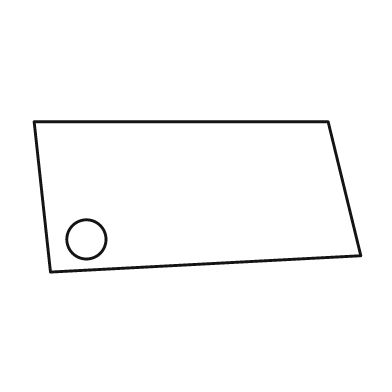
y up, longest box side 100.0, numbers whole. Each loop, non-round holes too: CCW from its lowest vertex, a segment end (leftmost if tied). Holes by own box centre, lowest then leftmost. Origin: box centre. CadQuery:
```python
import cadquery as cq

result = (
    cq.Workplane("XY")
    .moveTo(-45.0, -23.0)
    .lineTo(50.0, -18.0)
    .lineTo(40.0, 23.0)
    .lineTo(-50.0, 23.0)
    .close()
    .moveTo(-34.0, -13.0)
    .circle(6.0)
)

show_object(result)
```